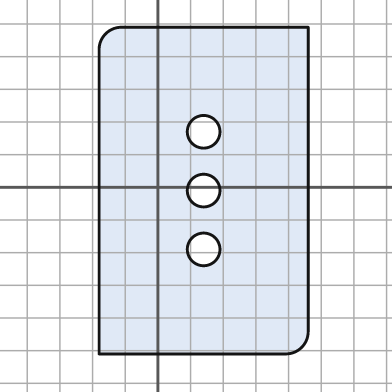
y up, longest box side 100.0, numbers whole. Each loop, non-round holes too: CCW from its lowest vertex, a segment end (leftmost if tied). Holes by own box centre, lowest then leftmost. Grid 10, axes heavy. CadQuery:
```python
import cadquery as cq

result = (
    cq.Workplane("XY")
    .moveTo(-18.0, -51.0)
    .lineTo(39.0, -51.0)
    .threePointArc((44.0, -49.0), (46.0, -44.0))
    .lineTo(46.0, 49.0)
    .lineTo(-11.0, 49.0)
    .threePointArc((-16.0, 47.0), (-18.0, 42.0))
    .close()
    .moveTo(14.0, -19.0)
    .circle(5.0)
    .moveTo(14.0, -1.0)
    .circle(5.0)
    .moveTo(14.0, 17.0)
    .circle(5.0)
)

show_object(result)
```